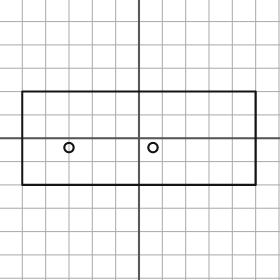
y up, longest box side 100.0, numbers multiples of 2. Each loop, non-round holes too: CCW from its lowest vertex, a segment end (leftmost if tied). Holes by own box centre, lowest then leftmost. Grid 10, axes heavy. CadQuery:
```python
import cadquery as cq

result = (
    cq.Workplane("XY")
    .moveTo(-50.0, -20.0)
    .lineTo(50.0, -20.0)
    .lineTo(50.0, 20.0)
    .lineTo(-50.0, 20.0)
    .close()
    .moveTo(-30.0, -4.0)
    .circle(2.0)
    .moveTo(6.0, -4.0)
    .circle(2.0)
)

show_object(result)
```